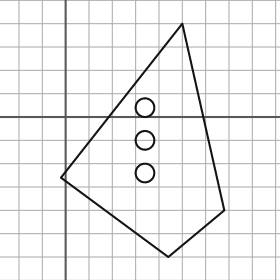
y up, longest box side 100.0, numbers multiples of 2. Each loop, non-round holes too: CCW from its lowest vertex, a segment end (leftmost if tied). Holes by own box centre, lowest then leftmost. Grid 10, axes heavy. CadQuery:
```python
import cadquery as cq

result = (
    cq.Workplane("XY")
    .moveTo(44.0, -60.0)
    .lineTo(68.0, -40.0)
    .lineTo(50.0, 40.0)
    .lineTo(-2.0, -26.0)
    .close()
    .moveTo(34.0, -24.0)
    .circle(4.0)
    .moveTo(34.0, -10.0)
    .circle(4.0)
    .moveTo(34.0, 4.0)
    .circle(4.0)
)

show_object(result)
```